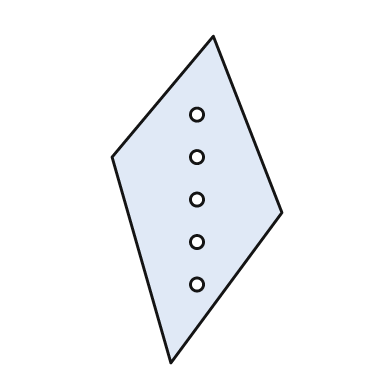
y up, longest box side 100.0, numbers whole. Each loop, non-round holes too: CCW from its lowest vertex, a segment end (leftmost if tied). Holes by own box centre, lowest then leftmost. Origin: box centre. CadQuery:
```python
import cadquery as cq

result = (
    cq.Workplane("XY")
    .moveTo(-8.0, -50.0)
    .lineTo(26.0, -4.0)
    .lineTo(5.0, 50.0)
    .lineTo(-26.0, 13.0)
    .close()
    .moveTo(0.0, -26.0)
    .circle(2.0)
    .moveTo(0.0, -13.0)
    .circle(2.0)
    .moveTo(0.0, 0.0)
    .circle(2.0)
    .moveTo(0.0, 13.0)
    .circle(2.0)
    .moveTo(0.0, 26.0)
    .circle(2.0)
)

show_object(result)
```